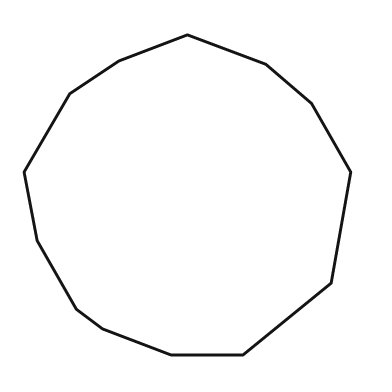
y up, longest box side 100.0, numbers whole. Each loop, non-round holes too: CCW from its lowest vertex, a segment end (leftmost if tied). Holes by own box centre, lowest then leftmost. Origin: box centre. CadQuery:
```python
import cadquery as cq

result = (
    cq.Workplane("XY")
    .moveTo(-5.0, -49.0)
    .lineTo(17.0, -49.0)
    .lineTo(44.0, -27.0)
    .lineTo(50.0, 7.0)
    .lineTo(38.0, 28.0)
    .lineTo(24.0, 40.0)
    .lineTo(0.0, 49.0)
    .lineTo(-21.0, 41.0)
    .lineTo(-36.0, 31.0)
    .lineTo(-50.0, 7.0)
    .lineTo(-46.0, -14.0)
    .lineTo(-34.0, -35.0)
    .lineTo(-26.0, -41.0)
    .close()
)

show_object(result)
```